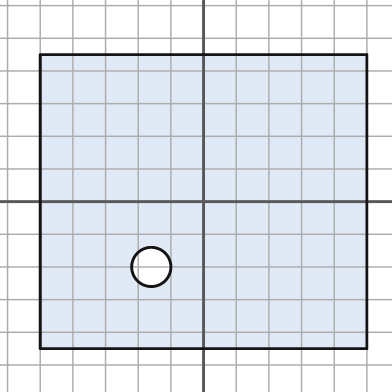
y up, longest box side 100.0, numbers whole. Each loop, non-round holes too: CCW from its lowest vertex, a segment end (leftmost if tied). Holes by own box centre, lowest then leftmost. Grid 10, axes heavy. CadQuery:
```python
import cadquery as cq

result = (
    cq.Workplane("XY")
    .moveTo(-50.0, -45.0)
    .lineTo(50.0, -45.0)
    .lineTo(50.0, 45.0)
    .lineTo(-50.0, 45.0)
    .close()
    .moveTo(-16.0, -20.0)
    .circle(6.0)
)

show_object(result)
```